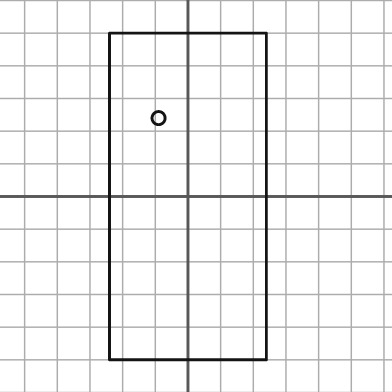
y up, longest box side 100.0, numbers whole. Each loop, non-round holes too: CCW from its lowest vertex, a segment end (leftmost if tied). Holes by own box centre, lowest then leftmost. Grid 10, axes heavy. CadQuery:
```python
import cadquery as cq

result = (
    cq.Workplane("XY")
    .moveTo(-24.0, -50.0)
    .lineTo(24.0, -50.0)
    .lineTo(24.0, 50.0)
    .lineTo(-24.0, 50.0)
    .close()
    .moveTo(-9.0, 24.0)
    .circle(2.0)
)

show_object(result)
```